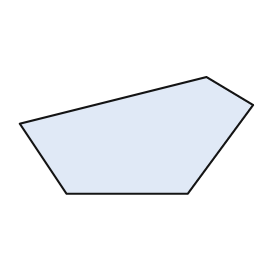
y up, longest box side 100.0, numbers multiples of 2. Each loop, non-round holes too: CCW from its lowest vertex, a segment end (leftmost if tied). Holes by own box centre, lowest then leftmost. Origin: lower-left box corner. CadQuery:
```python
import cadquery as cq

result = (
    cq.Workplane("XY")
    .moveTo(20.0, 0.0)
    .lineTo(72.0, 0.0)
    .lineTo(100.0, 38.0)
    .lineTo(80.0, 50.0)
    .lineTo(0.0, 30.0)
    .close()
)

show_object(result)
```